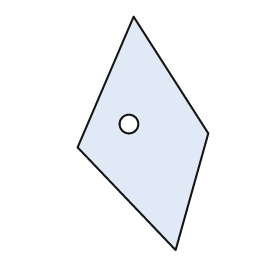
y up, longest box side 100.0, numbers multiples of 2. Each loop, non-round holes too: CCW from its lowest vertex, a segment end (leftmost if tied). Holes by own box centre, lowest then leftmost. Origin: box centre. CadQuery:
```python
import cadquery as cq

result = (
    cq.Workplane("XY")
    .moveTo(14.0, -50.0)
    .lineTo(28.0, 0.0)
    .lineTo(-4.0, 50.0)
    .lineTo(-28.0, -6.0)
    .close()
    .moveTo(-6.0, 4.0)
    .circle(4.0)
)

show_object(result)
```